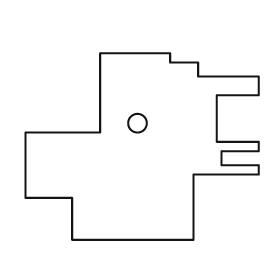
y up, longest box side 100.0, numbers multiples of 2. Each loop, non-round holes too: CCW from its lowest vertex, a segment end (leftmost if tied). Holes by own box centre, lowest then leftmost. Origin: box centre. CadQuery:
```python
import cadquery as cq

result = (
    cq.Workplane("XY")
    .moveTo(-30.0, -40.0)
    .lineTo(22.0, -40.0)
    .lineTo(22.0, -12.0)
    .lineTo(50.0, -12.0)
    .lineTo(50.0, -8.0)
    .lineTo(34.0, -8.0)
    .lineTo(34.0, -2.0)
    .lineTo(50.0, -2.0)
    .lineTo(50.0, 2.0)
    .lineTo(32.0, 2.0)
    .lineTo(32.0, 22.0)
    .lineTo(50.0, 22.0)
    .lineTo(50.0, 30.0)
    .lineTo(24.0, 30.0)
    .lineTo(24.0, 36.0)
    .lineTo(12.0, 36.0)
    .lineTo(12.0, 40.0)
    .lineTo(-18.0, 40.0)
    .lineTo(-18.0, 6.0)
    .lineTo(-50.0, 6.0)
    .lineTo(-50.0, -22.0)
    .lineTo(-30.0, -22.0)
    .close()
    .moveTo(-2.0, 10.0)
    .circle(4.0)
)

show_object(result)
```